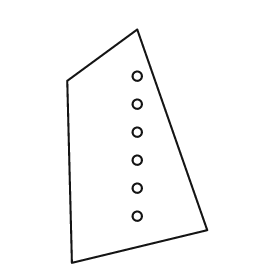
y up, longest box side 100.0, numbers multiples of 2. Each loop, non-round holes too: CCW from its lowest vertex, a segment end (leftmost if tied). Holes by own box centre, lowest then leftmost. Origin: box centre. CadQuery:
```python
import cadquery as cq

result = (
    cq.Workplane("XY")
    .moveTo(-28.0, -50.0)
    .lineTo(30.0, -36.0)
    .lineTo(0.0, 50.0)
    .lineTo(-30.0, 28.0)
    .close()
    .moveTo(0.0, -30.0)
    .circle(2.0)
    .moveTo(0.0, -18.0)
    .circle(2.0)
    .moveTo(0.0, -6.0)
    .circle(2.0)
    .moveTo(0.0, 6.0)
    .circle(2.0)
    .moveTo(0.0, 18.0)
    .circle(2.0)
    .moveTo(0.0, 30.0)
    .circle(2.0)
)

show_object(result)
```